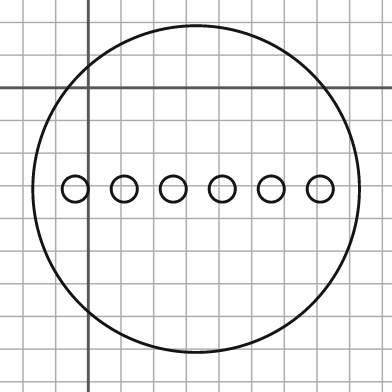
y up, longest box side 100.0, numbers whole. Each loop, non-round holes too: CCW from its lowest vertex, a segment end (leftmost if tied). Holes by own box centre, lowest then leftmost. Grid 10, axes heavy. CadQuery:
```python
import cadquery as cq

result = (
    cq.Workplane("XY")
    .moveTo(33.0, -31.0)
    .circle(50.0)
    .moveTo(-4.0, -31.0)
    .circle(4.0)
    .moveTo(11.0, -31.0)
    .circle(4.0)
    .moveTo(26.0, -31.0)
    .circle(4.0)
    .moveTo(41.0, -31.0)
    .circle(4.0)
    .moveTo(56.0, -31.0)
    .circle(4.0)
    .moveTo(71.0, -31.0)
    .circle(4.0)
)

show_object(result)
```